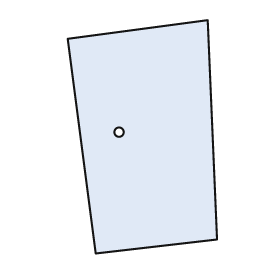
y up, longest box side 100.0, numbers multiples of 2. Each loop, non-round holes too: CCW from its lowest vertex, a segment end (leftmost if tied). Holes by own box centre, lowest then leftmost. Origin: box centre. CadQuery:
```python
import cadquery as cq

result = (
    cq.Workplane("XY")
    .moveTo(-20.0, -50.0)
    .lineTo(32.0, -44.0)
    .lineTo(28.0, 50.0)
    .lineTo(-32.0, 42.0)
    .close()
    .moveTo(-10.0, 2.0)
    .circle(2.0)
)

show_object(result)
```